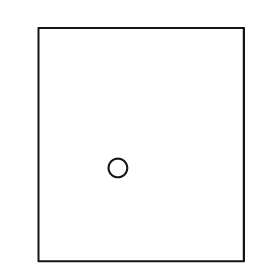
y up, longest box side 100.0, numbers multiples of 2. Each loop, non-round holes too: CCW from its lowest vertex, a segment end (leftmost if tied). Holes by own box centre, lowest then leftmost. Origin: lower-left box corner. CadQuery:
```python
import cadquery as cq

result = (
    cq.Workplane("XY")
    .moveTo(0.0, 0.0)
    .lineTo(88.0, 0.0)
    .lineTo(88.0, 100.0)
    .lineTo(0.0, 100.0)
    .close()
    .moveTo(34.0, 40.0)
    .circle(4.0)
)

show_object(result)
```